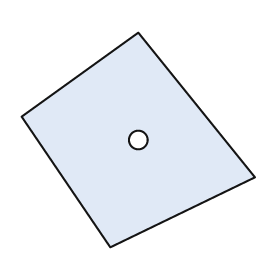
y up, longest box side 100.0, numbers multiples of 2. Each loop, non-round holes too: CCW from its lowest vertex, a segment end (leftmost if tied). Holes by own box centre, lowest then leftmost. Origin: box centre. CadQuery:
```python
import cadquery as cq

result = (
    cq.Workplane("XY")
    .moveTo(-12.0, -46.0)
    .lineTo(50.0, -16.0)
    .lineTo(0.0, 46.0)
    .lineTo(-50.0, 10.0)
    .close()
    .moveTo(0.0, 0.0)
    .circle(4.0)
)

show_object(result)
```